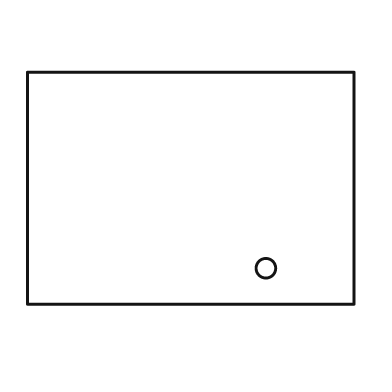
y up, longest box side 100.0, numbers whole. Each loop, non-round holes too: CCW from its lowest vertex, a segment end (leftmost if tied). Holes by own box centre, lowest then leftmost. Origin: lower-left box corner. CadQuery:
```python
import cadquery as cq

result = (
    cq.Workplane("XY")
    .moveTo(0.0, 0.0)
    .lineTo(100.0, 0.0)
    .lineTo(100.0, 71.0)
    .lineTo(0.0, 71.0)
    .close()
    .moveTo(73.0, 11.0)
    .circle(3.0)
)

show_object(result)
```